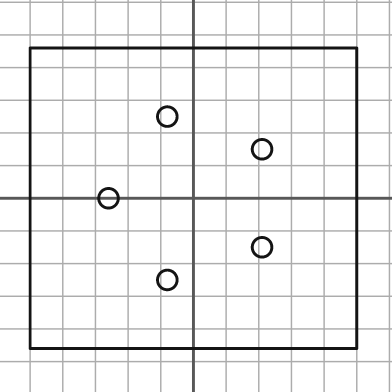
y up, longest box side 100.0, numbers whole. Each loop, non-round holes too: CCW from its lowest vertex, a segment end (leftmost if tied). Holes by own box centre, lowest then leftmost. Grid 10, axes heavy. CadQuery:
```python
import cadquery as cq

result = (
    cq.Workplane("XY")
    .moveTo(-50.0, -46.0)
    .lineTo(50.0, -46.0)
    .lineTo(50.0, 46.0)
    .lineTo(-50.0, 46.0)
    .close()
    .moveTo(-8.0, -25.0)
    .circle(3.0)
    .moveTo(21.0, -15.0)
    .circle(3.0)
    .moveTo(-26.0, 0.0)
    .circle(3.0)
    .moveTo(21.0, 15.0)
    .circle(3.0)
    .moveTo(-8.0, 25.0)
    .circle(3.0)
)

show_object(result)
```